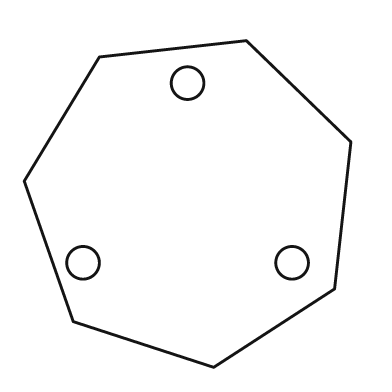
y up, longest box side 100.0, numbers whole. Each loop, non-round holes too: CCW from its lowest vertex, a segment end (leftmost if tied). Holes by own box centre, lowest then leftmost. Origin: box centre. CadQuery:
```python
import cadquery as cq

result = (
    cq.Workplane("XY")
    .moveTo(8.0, -50.0)
    .lineTo(45.0, -26.0)
    .lineTo(50.0, 19.0)
    .lineTo(18.0, 50.0)
    .lineTo(-27.0, 45.0)
    .lineTo(-50.0, 7.0)
    .lineTo(-35.0, -36.0)
    .close()
    .moveTo(-32.0, -18.0)
    .circle(5.0)
    .moveTo(32.0, -18.0)
    .circle(5.0)
    .moveTo(0.0, 37.0)
    .circle(5.0)
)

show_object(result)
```